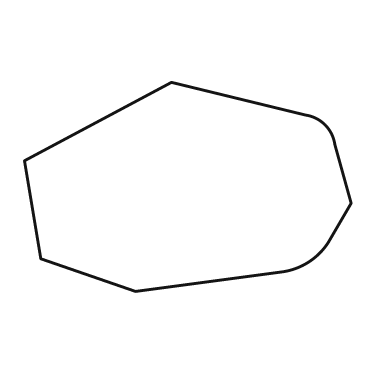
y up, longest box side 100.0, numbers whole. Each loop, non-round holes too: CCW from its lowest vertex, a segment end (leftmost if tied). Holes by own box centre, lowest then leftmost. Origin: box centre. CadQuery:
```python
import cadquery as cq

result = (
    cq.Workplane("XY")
    .moveTo(-16.0, -32.0)
    .lineTo(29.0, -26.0)
    .threePointArc((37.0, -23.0), (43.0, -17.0))
    .lineTo(50.0, -5.0)
    .lineTo(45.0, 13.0)
    .threePointArc((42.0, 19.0), (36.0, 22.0))
    .lineTo(-5.0, 32.0)
    .lineTo(-50.0, 8.0)
    .lineTo(-45.0, -22.0)
    .close()
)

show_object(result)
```